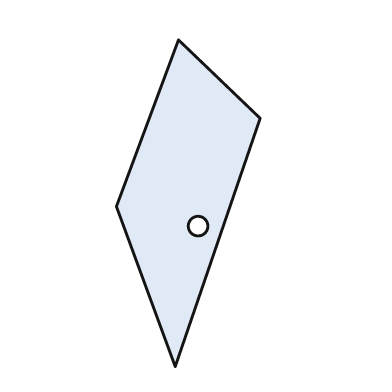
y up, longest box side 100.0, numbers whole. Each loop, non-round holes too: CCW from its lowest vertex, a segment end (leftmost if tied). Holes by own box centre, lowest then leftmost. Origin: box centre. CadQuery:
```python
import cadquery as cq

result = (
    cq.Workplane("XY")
    .moveTo(-4.0, -50.0)
    .lineTo(22.0, 26.0)
    .lineTo(-3.0, 50.0)
    .lineTo(-22.0, -1.0)
    .close()
    .moveTo(3.0, -7.0)
    .circle(3.0)
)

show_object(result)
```